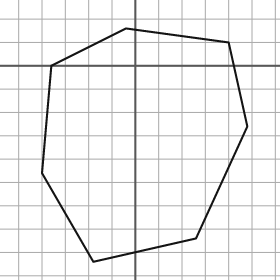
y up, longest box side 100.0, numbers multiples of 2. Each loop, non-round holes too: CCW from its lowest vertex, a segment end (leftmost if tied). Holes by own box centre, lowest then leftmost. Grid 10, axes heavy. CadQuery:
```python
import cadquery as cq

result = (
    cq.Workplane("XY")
    .moveTo(-18.0, -84.0)
    .lineTo(26.0, -74.0)
    .lineTo(48.0, -26.0)
    .lineTo(40.0, 10.0)
    .lineTo(-4.0, 16.0)
    .lineTo(-36.0, 0.0)
    .lineTo(-40.0, -46.0)
    .close()
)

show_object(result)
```